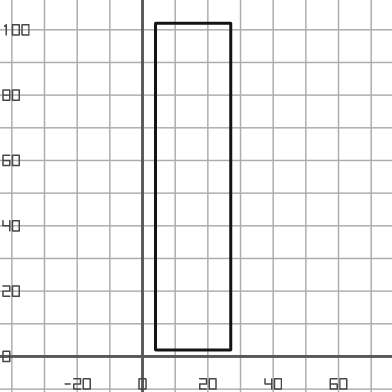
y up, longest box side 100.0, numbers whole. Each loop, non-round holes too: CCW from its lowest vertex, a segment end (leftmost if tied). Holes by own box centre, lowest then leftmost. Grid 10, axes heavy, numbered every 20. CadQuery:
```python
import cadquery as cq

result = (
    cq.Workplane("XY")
    .moveTo(4.0, 2.0)
    .lineTo(27.0, 2.0)
    .lineTo(27.0, 102.0)
    .lineTo(4.0, 102.0)
    .close()
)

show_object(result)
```